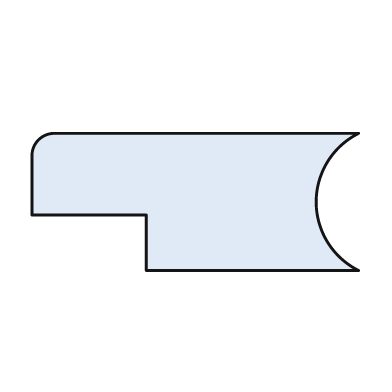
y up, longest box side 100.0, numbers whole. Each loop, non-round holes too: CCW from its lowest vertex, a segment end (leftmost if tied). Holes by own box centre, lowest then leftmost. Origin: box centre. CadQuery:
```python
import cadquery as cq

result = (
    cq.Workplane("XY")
    .moveTo(-15.0, -21.0)
    .lineTo(50.0, -21.0)
    .threePointArc((37.0, 0.0), (50.0, 21.0))
    .lineTo(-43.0, 21.0)
    .threePointArc((-48.0, 19.0), (-50.0, 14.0))
    .lineTo(-50.0, -4.0)
    .lineTo(-15.0, -4.0)
    .close()
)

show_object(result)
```